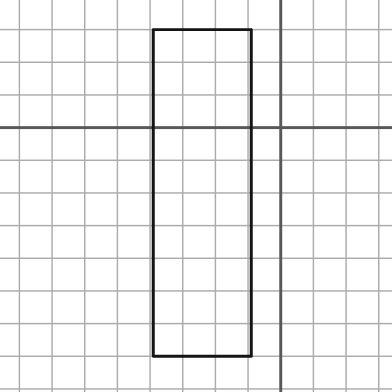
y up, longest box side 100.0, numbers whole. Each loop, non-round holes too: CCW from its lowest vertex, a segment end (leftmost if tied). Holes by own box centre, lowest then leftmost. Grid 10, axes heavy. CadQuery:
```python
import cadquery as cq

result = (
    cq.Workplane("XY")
    .moveTo(-39.0, -70.0)
    .lineTo(-9.0, -70.0)
    .lineTo(-9.0, 30.0)
    .lineTo(-39.0, 30.0)
    .close()
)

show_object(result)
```